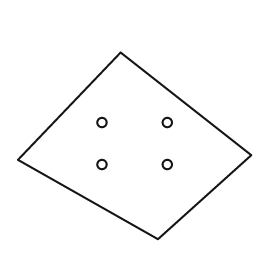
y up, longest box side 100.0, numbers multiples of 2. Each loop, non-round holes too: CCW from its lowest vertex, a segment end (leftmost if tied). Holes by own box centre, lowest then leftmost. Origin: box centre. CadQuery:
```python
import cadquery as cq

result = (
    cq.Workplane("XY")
    .moveTo(10.0, -40.0)
    .lineTo(50.0, -4.0)
    .lineTo(-6.0, 40.0)
    .lineTo(-50.0, -6.0)
    .close()
    .moveTo(-14.0, -8.0)
    .circle(2.0)
    .moveTo(14.0, -8.0)
    .circle(2.0)
    .moveTo(-14.0, 10.0)
    .circle(2.0)
    .moveTo(14.0, 10.0)
    .circle(2.0)
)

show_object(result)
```